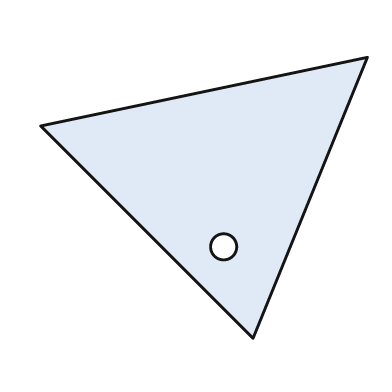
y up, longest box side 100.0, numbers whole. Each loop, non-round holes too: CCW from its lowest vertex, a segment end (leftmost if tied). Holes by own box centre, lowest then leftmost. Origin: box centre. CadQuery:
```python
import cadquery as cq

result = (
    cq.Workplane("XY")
    .moveTo(15.0, -43.0)
    .lineTo(50.0, 43.0)
    .lineTo(-50.0, 22.0)
    .close()
    .moveTo(6.0, -15.0)
    .circle(4.0)
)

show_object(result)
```